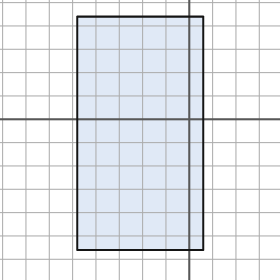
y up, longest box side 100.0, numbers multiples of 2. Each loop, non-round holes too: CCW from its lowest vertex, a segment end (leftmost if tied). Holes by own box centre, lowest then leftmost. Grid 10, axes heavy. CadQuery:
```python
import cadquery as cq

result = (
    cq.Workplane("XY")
    .moveTo(-48.0, -56.0)
    .lineTo(6.0, -56.0)
    .lineTo(6.0, 44.0)
    .lineTo(-48.0, 44.0)
    .close()
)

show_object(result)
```